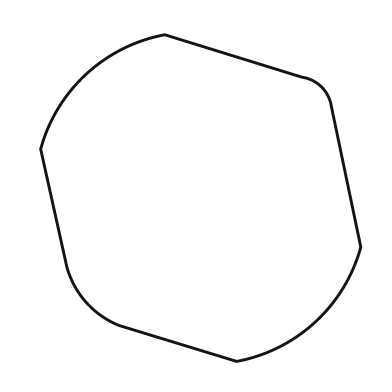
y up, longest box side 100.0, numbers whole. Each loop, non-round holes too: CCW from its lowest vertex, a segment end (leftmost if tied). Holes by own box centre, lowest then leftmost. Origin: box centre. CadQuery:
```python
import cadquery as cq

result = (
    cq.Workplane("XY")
    .moveTo(11.0, -50.0)
    .threePointArc((35.0, -38.0), (49.0, -15.0))
    .lineTo(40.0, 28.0)
    .threePointArc((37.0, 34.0), (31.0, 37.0))
    .lineTo(-11.0, 50.0)
    .threePointArc((-35.0, 38.0), (-49.0, 15.0))
    .lineTo(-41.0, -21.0)
    .threePointArc((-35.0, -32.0), (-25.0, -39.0))
    .close()
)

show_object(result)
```